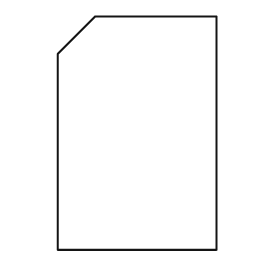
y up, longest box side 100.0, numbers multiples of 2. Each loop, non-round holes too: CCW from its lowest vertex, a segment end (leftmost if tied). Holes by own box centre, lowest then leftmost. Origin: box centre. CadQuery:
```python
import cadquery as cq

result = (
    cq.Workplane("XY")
    .moveTo(-34.0, -50.0)
    .lineTo(34.0, -50.0)
    .lineTo(34.0, 50.0)
    .lineTo(-18.0, 50.0)
    .lineTo(-34.0, 34.0)
    .close()
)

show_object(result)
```